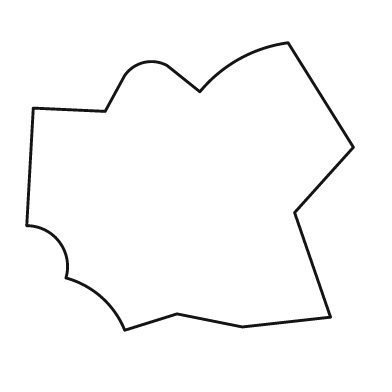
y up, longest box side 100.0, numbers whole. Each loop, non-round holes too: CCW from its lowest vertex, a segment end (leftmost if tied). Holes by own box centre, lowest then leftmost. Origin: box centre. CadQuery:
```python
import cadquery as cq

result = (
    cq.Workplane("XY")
    .moveTo(-20.0, -44.0)
    .lineTo(-4.0, -39.0)
    .lineTo(16.0, -43.0)
    .lineTo(43.0, -40.0)
    .lineTo(32.0, -8.0)
    .lineTo(50.0, 12.0)
    .lineTo(30.0, 44.0)
    .threePointArc((15.0, 39.0), (3.0, 29.0))
    .lineTo(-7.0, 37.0)
    .threePointArc((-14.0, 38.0), (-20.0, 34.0))
    .lineTo(-26.0, 23.0)
    .lineTo(-48.0, 24.0)
    .lineTo(-50.0, -12.0)
    .threePointArc((-40.0, -17.0), (-38.0, -28.0))
    .threePointArc((-27.0, -34.0), (-20.0, -44.0))
    .close()
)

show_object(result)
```